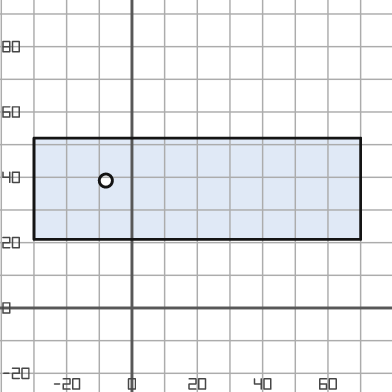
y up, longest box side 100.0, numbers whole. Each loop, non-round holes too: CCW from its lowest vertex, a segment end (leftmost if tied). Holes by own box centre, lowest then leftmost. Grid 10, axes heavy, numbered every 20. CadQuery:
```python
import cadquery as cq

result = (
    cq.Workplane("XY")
    .moveTo(-30.0, 21.0)
    .lineTo(70.0, 21.0)
    .lineTo(70.0, 52.0)
    .lineTo(-30.0, 52.0)
    .close()
    .moveTo(-8.0, 39.0)
    .circle(2.0)
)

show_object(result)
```